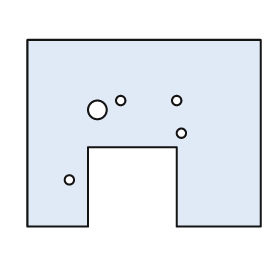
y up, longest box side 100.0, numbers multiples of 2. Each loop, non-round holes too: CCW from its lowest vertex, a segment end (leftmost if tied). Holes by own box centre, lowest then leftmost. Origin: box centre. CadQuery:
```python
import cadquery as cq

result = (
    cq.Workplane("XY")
    .moveTo(-50.0, -40.0)
    .lineTo(-24.0, -40.0)
    .lineTo(-24.0, -6.0)
    .lineTo(14.0, -6.0)
    .lineTo(14.0, -40.0)
    .lineTo(50.0, -40.0)
    .lineTo(50.0, 40.0)
    .lineTo(-50.0, 40.0)
    .close()
    .moveTo(-32.0, -20.0)
    .circle(2.0)
    .moveTo(16.0, 0.0)
    .circle(2.0)
    .moveTo(-20.0, 10.0)
    .circle(4.0)
    .moveTo(-10.0, 14.0)
    .circle(2.0)
    .moveTo(14.0, 14.0)
    .circle(2.0)
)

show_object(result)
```